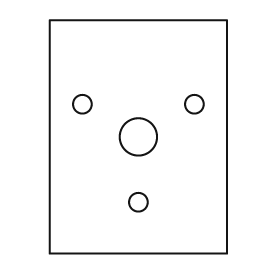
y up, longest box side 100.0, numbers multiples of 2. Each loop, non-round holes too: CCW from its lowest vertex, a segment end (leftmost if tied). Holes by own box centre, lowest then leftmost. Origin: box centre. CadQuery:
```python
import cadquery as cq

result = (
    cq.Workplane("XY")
    .moveTo(-38.0, -50.0)
    .lineTo(38.0, -50.0)
    .lineTo(38.0, 50.0)
    .lineTo(-38.0, 50.0)
    .close()
    .moveTo(0.0, -28.0)
    .circle(4.0)
    .moveTo(0.0, 0.0)
    .circle(8.0)
    .moveTo(-24.0, 14.0)
    .circle(4.0)
    .moveTo(24.0, 14.0)
    .circle(4.0)
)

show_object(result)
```